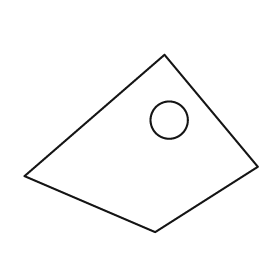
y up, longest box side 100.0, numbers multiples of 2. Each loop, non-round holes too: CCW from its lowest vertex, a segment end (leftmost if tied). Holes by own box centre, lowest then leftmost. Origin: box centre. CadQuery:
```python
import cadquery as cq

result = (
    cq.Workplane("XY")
    .moveTo(6.0, -38.0)
    .lineTo(50.0, -10.0)
    .lineTo(10.0, 38.0)
    .lineTo(-50.0, -14.0)
    .close()
    .moveTo(12.0, 10.0)
    .circle(8.0)
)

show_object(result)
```